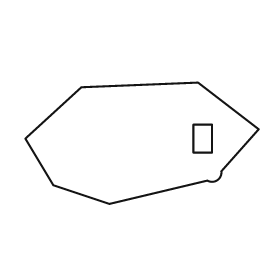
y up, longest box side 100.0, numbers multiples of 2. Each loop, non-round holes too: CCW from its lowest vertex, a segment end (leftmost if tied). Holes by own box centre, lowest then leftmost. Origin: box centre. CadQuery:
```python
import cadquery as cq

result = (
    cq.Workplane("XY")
    .moveTo(-14.0, -26.0)
    .lineTo(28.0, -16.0)
    .threePointArc((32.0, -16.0), (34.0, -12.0))
    .lineTo(50.0, 6.0)
    .lineTo(24.0, 26.0)
    .lineTo(-26.0, 24.0)
    .lineTo(-50.0, 2.0)
    .lineTo(-38.0, -18.0)
    .close()
    .moveTo(22.0, -4.0)
    .lineTo(30.0, -4.0)
    .lineTo(30.0, 8.0)
    .lineTo(22.0, 8.0)
    .close()
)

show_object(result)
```